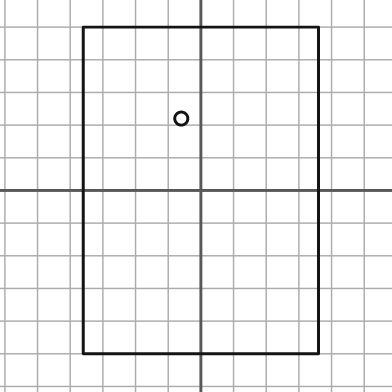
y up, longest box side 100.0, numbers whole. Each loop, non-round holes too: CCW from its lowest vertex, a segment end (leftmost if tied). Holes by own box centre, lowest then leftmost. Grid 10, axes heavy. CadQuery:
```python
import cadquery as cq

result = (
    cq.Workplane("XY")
    .moveTo(-36.0, -50.0)
    .lineTo(36.0, -50.0)
    .lineTo(36.0, 50.0)
    .lineTo(-36.0, 50.0)
    .close()
    .moveTo(-6.0, 22.0)
    .circle(2.0)
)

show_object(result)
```